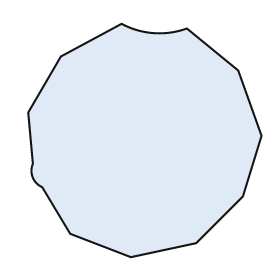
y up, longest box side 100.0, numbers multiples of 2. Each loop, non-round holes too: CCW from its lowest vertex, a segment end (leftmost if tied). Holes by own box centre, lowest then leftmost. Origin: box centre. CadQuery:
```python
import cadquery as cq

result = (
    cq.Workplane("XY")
    .moveTo(-6.0, -50.0)
    .lineTo(22.0, -44.0)
    .lineTo(42.0, -24.0)
    .lineTo(50.0, 2.0)
    .lineTo(40.0, 30.0)
    .lineTo(18.0, 48.0)
    .threePointArc((4.0, 46.0), (-10.0, 50.0))
    .lineTo(-36.0, 36.0)
    .lineTo(-50.0, 12.0)
    .lineTo(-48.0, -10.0)
    .threePointArc((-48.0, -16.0), (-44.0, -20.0))
    .lineTo(-32.0, -40.0)
    .close()
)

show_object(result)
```